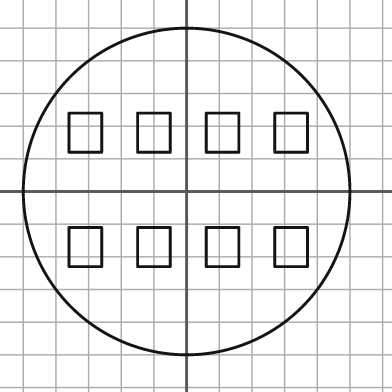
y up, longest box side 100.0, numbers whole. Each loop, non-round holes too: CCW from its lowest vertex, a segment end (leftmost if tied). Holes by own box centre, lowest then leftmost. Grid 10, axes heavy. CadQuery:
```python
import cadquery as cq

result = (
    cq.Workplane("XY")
    .moveTo(0.0, 0.0)
    .circle(50.0)
    .moveTo(-36.0, -23.0)
    .lineTo(-26.0, -23.0)
    .lineTo(-26.0, -11.0)
    .lineTo(-36.0, -11.0)
    .close()
    .moveTo(-15.0, -23.0)
    .lineTo(-5.0, -23.0)
    .lineTo(-5.0, -11.0)
    .lineTo(-15.0, -11.0)
    .close()
    .moveTo(6.0, -23.0)
    .lineTo(16.0, -23.0)
    .lineTo(16.0, -11.0)
    .lineTo(6.0, -11.0)
    .close()
    .moveTo(27.0, -23.0)
    .lineTo(37.0, -23.0)
    .lineTo(37.0, -11.0)
    .lineTo(27.0, -11.0)
    .close()
    .moveTo(-36.0, 12.0)
    .lineTo(-26.0, 12.0)
    .lineTo(-26.0, 24.0)
    .lineTo(-36.0, 24.0)
    .close()
    .moveTo(-15.0, 12.0)
    .lineTo(-5.0, 12.0)
    .lineTo(-5.0, 24.0)
    .lineTo(-15.0, 24.0)
    .close()
    .moveTo(6.0, 12.0)
    .lineTo(16.0, 12.0)
    .lineTo(16.0, 24.0)
    .lineTo(6.0, 24.0)
    .close()
    .moveTo(27.0, 12.0)
    .lineTo(37.0, 12.0)
    .lineTo(37.0, 24.0)
    .lineTo(27.0, 24.0)
    .close()
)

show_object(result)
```